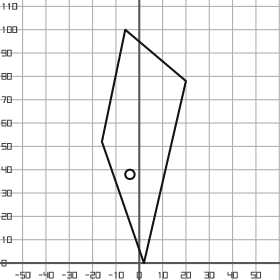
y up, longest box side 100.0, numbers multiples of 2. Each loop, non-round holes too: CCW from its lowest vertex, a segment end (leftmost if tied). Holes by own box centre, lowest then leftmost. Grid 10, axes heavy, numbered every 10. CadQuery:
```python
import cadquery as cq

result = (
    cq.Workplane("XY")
    .moveTo(2.0, 0.0)
    .lineTo(20.0, 78.0)
    .lineTo(-6.0, 100.0)
    .lineTo(-16.0, 52.0)
    .close()
    .moveTo(-4.0, 38.0)
    .circle(2.0)
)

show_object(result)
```